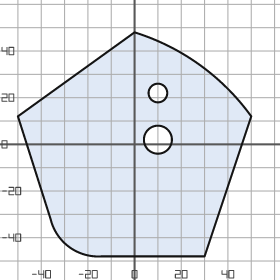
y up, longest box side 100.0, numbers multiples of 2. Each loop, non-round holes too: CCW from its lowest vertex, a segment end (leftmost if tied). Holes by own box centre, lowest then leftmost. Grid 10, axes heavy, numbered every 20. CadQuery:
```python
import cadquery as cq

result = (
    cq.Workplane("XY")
    .moveTo(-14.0, -48.0)
    .lineTo(30.0, -48.0)
    .lineTo(50.0, 12.0)
    .threePointArc((28.0, 34.0), (0.0, 48.0))
    .lineTo(-50.0, 12.0)
    .lineTo(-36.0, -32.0)
    .threePointArc((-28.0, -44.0), (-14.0, -48.0))
    .close()
    .moveTo(10.0, 2.0)
    .circle(6.0)
    .moveTo(10.0, 22.0)
    .circle(4.0)
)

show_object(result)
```